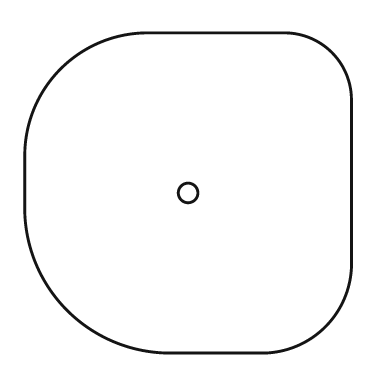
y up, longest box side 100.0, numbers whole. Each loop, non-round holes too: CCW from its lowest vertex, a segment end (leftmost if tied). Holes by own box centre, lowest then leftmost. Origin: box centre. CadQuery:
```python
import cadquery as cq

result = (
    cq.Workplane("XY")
    .moveTo(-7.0, -49.0)
    .lineTo(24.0, -49.0)
    .threePointArc((42.0, -41.0), (50.0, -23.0))
    .lineTo(50.0, 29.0)
    .threePointArc((44.0, 43.0), (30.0, 49.0))
    .lineTo(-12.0, 49.0)
    .threePointArc((-39.0, 38.0), (-50.0, 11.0))
    .lineTo(-50.0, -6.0)
    .threePointArc((-37.0, -36.0), (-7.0, -49.0))
    .close()
    .moveTo(0.0, 0.0)
    .circle(3.0)
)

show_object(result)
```